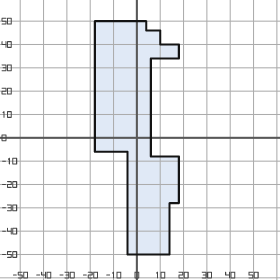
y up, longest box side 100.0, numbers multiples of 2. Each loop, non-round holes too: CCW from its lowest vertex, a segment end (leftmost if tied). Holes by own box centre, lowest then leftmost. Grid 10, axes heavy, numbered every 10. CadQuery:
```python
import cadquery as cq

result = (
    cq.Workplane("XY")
    .moveTo(-4.0, -50.0)
    .lineTo(14.0, -50.0)
    .lineTo(14.0, -28.0)
    .lineTo(18.0, -28.0)
    .lineTo(18.0, -8.0)
    .lineTo(6.0, -8.0)
    .lineTo(6.0, 34.0)
    .lineTo(18.0, 34.0)
    .lineTo(18.0, 40.0)
    .lineTo(10.0, 40.0)
    .lineTo(10.0, 46.0)
    .lineTo(4.0, 46.0)
    .lineTo(4.0, 50.0)
    .lineTo(-18.0, 50.0)
    .lineTo(-18.0, -6.0)
    .lineTo(-4.0, -6.0)
    .close()
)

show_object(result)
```